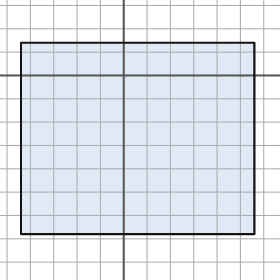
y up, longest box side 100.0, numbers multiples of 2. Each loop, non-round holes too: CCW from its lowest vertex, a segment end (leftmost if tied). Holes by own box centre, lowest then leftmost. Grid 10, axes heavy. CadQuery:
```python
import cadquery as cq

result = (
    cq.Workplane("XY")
    .moveTo(-44.0, -68.0)
    .lineTo(56.0, -68.0)
    .lineTo(56.0, 14.0)
    .lineTo(-44.0, 14.0)
    .close()
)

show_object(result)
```